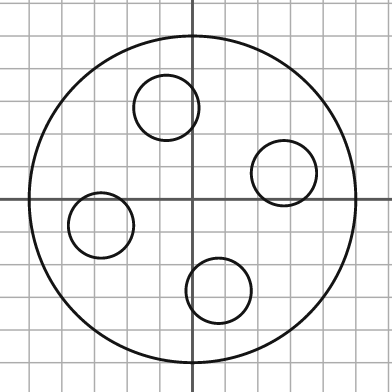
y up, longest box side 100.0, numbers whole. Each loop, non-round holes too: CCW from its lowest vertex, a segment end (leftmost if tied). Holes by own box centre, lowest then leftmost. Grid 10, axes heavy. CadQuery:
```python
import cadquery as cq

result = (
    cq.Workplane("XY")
    .moveTo(0.0, 0.0)
    .circle(50.0)
    .moveTo(8.0, -28.0)
    .circle(10.0)
    .moveTo(-28.0, -8.0)
    .circle(10.0)
    .moveTo(28.0, 8.0)
    .circle(10.0)
    .moveTo(-8.0, 28.0)
    .circle(10.0)
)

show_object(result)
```